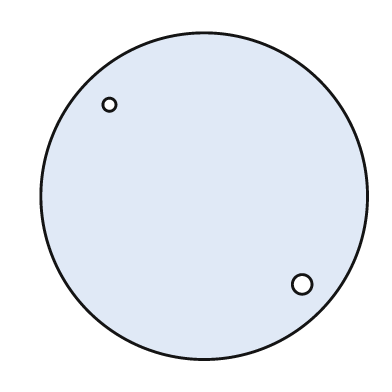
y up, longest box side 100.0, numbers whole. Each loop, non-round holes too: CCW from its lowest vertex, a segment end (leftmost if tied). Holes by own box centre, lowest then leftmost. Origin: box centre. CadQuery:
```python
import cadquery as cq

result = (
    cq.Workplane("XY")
    .moveTo(0.0, 0.0)
    .circle(50.0)
    .moveTo(30.0, -27.0)
    .circle(3.0)
    .moveTo(-29.0, 28.0)
    .circle(2.0)
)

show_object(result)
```